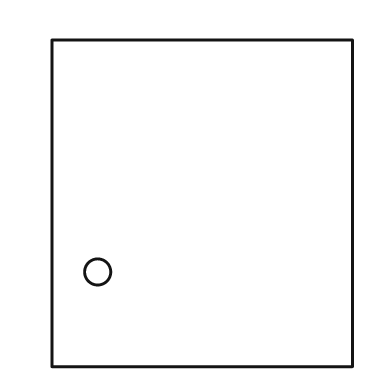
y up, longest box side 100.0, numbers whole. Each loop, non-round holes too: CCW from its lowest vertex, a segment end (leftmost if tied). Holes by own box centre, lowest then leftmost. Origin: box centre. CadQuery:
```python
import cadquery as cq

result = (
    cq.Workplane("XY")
    .moveTo(-46.0, -50.0)
    .lineTo(46.0, -50.0)
    .lineTo(46.0, 50.0)
    .lineTo(-46.0, 50.0)
    .close()
    .moveTo(-32.0, -21.0)
    .circle(4.0)
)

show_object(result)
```